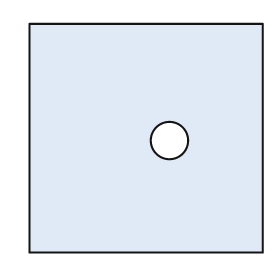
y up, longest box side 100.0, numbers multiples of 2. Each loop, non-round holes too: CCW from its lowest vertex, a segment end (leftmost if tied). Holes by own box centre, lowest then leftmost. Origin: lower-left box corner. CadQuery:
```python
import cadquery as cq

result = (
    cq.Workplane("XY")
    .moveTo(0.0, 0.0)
    .lineTo(100.0, 0.0)
    .lineTo(100.0, 98.0)
    .lineTo(0.0, 98.0)
    .close()
    .moveTo(60.0, 48.0)
    .circle(8.0)
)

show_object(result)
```